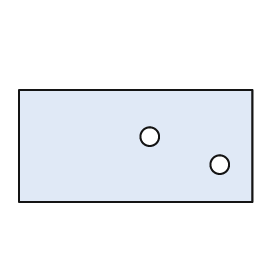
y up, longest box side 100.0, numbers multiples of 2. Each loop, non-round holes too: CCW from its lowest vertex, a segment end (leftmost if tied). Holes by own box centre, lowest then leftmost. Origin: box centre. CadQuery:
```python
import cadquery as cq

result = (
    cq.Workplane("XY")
    .moveTo(-50.0, -24.0)
    .lineTo(50.0, -24.0)
    .lineTo(50.0, 24.0)
    .lineTo(-50.0, 24.0)
    .close()
    .moveTo(36.0, -8.0)
    .circle(4.0)
    .moveTo(6.0, 4.0)
    .circle(4.0)
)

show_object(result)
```